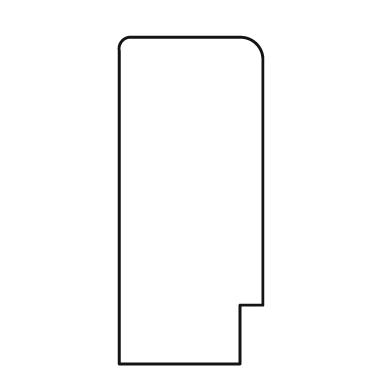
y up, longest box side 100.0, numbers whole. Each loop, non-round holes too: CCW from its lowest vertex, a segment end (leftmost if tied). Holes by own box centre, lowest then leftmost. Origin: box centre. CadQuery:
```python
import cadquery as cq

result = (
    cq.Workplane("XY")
    .moveTo(-22.0, -50.0)
    .lineTo(15.0, -50.0)
    .lineTo(15.0, -32.0)
    .lineTo(22.0, -32.0)
    .lineTo(22.0, 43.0)
    .threePointArc((20.0, 48.0), (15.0, 50.0))
    .lineTo(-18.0, 50.0)
    .threePointArc((-21.0, 49.0), (-22.0, 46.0))
    .close()
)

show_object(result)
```